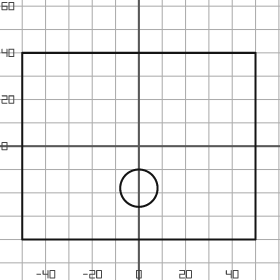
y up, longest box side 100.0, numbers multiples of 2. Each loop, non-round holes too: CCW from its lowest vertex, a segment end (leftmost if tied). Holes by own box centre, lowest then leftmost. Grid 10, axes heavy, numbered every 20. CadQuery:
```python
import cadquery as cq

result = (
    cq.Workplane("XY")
    .moveTo(-50.0, -40.0)
    .lineTo(50.0, -40.0)
    .lineTo(50.0, 40.0)
    .lineTo(-50.0, 40.0)
    .close()
    .moveTo(0.0, -18.0)
    .circle(8.0)
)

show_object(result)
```